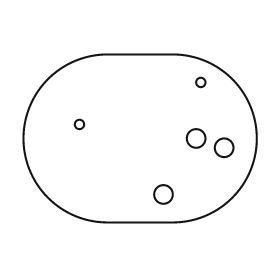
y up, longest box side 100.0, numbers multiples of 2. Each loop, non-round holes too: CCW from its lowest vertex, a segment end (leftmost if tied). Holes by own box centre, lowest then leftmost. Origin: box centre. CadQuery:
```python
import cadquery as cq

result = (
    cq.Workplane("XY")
    .moveTo(-14.0, -36.0)
    .lineTo(14.0, -36.0)
    .threePointArc((50.0, 0.0), (14.0, 36.0))
    .lineTo(-14.0, 36.0)
    .threePointArc((-50.0, 0.0), (-14.0, -36.0))
    .close()
    .moveTo(10.0, -24.0)
    .circle(4.0)
    .moveTo(36.0, -4.0)
    .circle(4.0)
    .moveTo(24.0, 0.0)
    .circle(4.0)
    .moveTo(-26.0, 6.0)
    .circle(2.0)
    .moveTo(26.0, 24.0)
    .circle(2.0)
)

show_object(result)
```